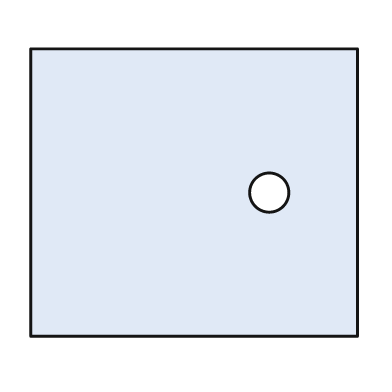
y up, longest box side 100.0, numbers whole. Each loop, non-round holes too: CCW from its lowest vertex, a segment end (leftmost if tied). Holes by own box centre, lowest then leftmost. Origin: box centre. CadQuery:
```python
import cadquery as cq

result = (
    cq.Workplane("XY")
    .moveTo(-50.0, -44.0)
    .lineTo(50.0, -44.0)
    .lineTo(50.0, 44.0)
    .lineTo(-50.0, 44.0)
    .close()
    .moveTo(23.0, 0.0)
    .circle(6.0)
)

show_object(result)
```